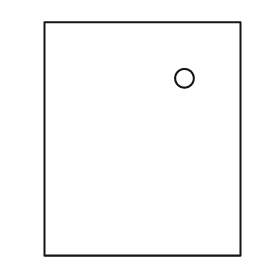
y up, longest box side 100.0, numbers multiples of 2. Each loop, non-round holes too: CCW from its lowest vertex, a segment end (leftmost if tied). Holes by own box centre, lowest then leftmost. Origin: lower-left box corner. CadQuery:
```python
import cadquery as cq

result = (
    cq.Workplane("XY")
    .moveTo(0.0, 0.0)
    .lineTo(84.0, 0.0)
    .lineTo(84.0, 100.0)
    .lineTo(0.0, 100.0)
    .close()
    .moveTo(60.0, 76.0)
    .circle(4.0)
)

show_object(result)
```